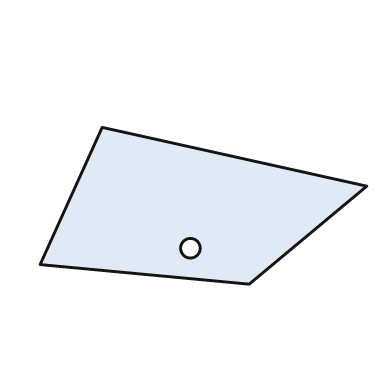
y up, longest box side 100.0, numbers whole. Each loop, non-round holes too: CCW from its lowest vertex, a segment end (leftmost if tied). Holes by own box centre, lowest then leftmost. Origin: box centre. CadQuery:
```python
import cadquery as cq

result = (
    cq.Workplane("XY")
    .moveTo(14.0, -24.0)
    .lineTo(50.0, 6.0)
    .lineTo(-31.0, 24.0)
    .lineTo(-50.0, -18.0)
    .close()
    .moveTo(-4.0, -13.0)
    .circle(3.0)
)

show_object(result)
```